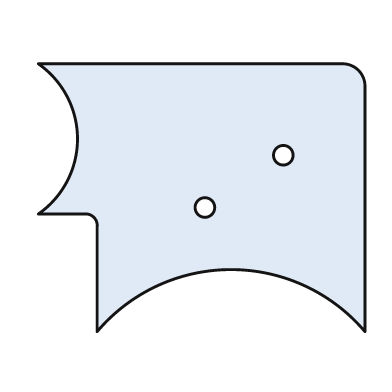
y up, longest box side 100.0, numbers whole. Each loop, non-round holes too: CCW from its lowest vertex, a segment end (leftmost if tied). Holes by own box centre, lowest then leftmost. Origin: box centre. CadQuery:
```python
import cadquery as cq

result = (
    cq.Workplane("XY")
    .moveTo(-32.0, -41.0)
    .threePointArc((9.0, -22.0), (50.0, -41.0))
    .lineTo(50.0, 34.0)
    .threePointArc((48.0, 39.0), (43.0, 41.0))
    .lineTo(-50.0, 41.0)
    .threePointArc((-38.0, 18.0), (-50.0, -5.0))
    .lineTo(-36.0, -5.0)
    .threePointArc((-33.0, -6.0), (-32.0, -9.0))
    .close()
    .moveTo(1.0, -3.0)
    .circle(3.0)
    .moveTo(25.0, 13.0)
    .circle(3.0)
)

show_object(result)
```